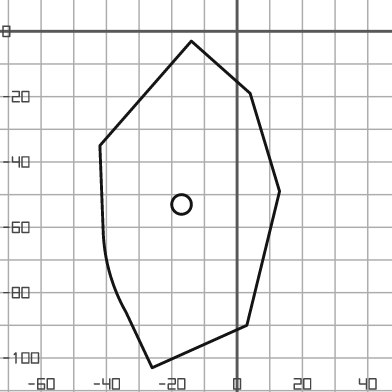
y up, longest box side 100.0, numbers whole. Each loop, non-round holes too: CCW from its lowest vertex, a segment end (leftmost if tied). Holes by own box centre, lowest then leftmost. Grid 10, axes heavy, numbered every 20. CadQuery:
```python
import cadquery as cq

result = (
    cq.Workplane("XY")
    .moveTo(-26.0, -103.0)
    .lineTo(3.0, -90.0)
    .lineTo(13.0, -49.0)
    .lineTo(4.0, -19.0)
    .lineTo(-14.0, -3.0)
    .lineTo(-42.0, -35.0)
    .lineTo(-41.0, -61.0)
    .threePointArc((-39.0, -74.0), (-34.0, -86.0))
    .close()
    .moveTo(-17.0, -53.0)
    .circle(3.0)
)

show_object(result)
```